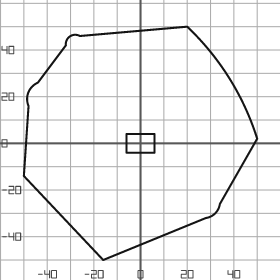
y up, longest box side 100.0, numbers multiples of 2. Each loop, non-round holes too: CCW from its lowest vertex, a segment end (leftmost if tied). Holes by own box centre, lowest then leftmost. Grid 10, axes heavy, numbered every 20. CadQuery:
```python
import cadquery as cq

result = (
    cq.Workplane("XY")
    .moveTo(-16.0, -50.0)
    .lineTo(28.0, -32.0)
    .threePointArc((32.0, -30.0), (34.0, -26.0))
    .lineTo(50.0, 2.0)
    .threePointArc((38.0, 28.0), (20.0, 50.0))
    .lineTo(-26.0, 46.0)
    .threePointArc((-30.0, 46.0), (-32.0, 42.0))
    .lineTo(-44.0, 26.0)
    .threePointArc((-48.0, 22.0), (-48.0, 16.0))
    .lineTo(-50.0, -14.0)
    .close()
    .moveTo(-6.0, -4.0)
    .lineTo(6.0, -4.0)
    .lineTo(6.0, 4.0)
    .lineTo(-6.0, 4.0)
    .close()
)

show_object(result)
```